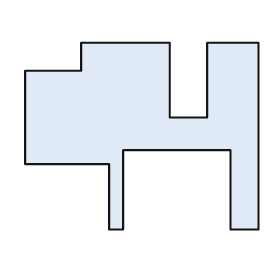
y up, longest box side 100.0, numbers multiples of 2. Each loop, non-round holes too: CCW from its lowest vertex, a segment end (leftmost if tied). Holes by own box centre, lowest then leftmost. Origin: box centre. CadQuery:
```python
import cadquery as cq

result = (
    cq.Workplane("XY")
    .moveTo(-14.0, -40.0)
    .lineTo(-8.0, -40.0)
    .lineTo(-8.0, -6.0)
    .lineTo(38.0, -6.0)
    .lineTo(38.0, -40.0)
    .lineTo(50.0, -40.0)
    .lineTo(50.0, 40.0)
    .lineTo(28.0, 40.0)
    .lineTo(28.0, 8.0)
    .lineTo(12.0, 8.0)
    .lineTo(12.0, 40.0)
    .lineTo(-26.0, 40.0)
    .lineTo(-26.0, 28.0)
    .lineTo(-50.0, 28.0)
    .lineTo(-50.0, -12.0)
    .lineTo(-14.0, -12.0)
    .close()
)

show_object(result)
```